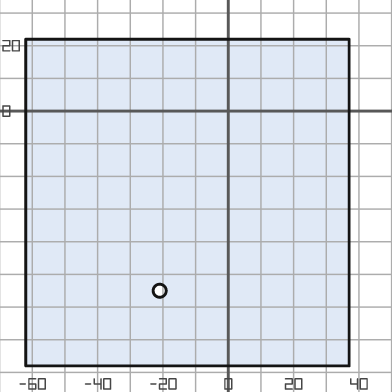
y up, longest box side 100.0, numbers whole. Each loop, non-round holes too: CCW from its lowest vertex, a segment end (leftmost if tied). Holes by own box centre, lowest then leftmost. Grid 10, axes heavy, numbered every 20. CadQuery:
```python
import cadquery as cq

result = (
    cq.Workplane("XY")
    .moveTo(-62.0, -78.0)
    .lineTo(37.0, -78.0)
    .lineTo(37.0, 22.0)
    .lineTo(-62.0, 22.0)
    .close()
    .moveTo(-21.0, -55.0)
    .circle(2.0)
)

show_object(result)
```